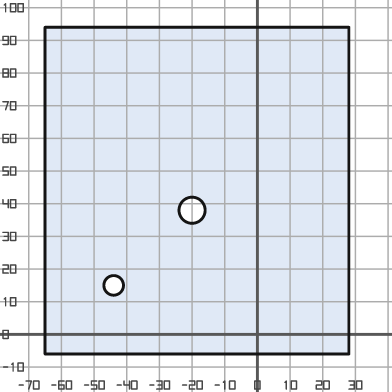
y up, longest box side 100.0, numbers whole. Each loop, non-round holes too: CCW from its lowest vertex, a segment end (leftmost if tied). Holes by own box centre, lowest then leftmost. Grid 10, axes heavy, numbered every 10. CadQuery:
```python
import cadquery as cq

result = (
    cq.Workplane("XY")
    .moveTo(-65.0, -6.0)
    .lineTo(28.0, -6.0)
    .lineTo(28.0, 94.0)
    .lineTo(-65.0, 94.0)
    .close()
    .moveTo(-44.0, 15.0)
    .circle(3.0)
    .moveTo(-20.0, 38.0)
    .circle(4.0)
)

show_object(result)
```